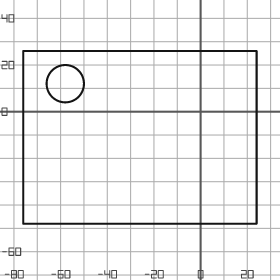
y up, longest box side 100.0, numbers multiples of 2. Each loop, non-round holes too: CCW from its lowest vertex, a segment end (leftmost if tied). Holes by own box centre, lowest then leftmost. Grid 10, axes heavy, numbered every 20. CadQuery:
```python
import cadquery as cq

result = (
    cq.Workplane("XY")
    .moveTo(-76.0, -48.0)
    .lineTo(24.0, -48.0)
    .lineTo(24.0, 26.0)
    .lineTo(-76.0, 26.0)
    .close()
    .moveTo(-58.0, 12.0)
    .circle(8.0)
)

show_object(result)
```